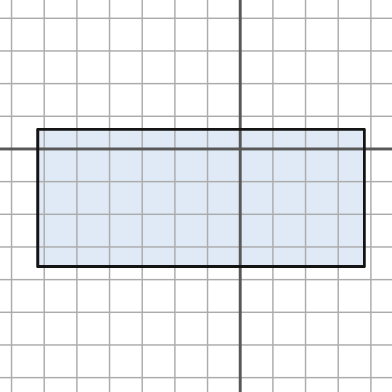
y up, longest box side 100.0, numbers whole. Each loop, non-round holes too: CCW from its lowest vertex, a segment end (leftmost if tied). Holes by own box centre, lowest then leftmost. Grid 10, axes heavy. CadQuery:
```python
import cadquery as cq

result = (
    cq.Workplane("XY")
    .moveTo(-62.0, -36.0)
    .lineTo(38.0, -36.0)
    .lineTo(38.0, 6.0)
    .lineTo(-62.0, 6.0)
    .close()
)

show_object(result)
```